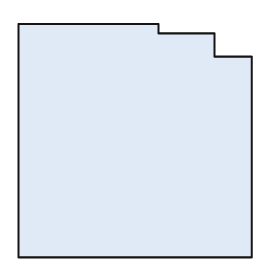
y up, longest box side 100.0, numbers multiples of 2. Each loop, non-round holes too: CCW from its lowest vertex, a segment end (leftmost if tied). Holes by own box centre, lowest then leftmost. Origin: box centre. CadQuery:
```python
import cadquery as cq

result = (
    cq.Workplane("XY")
    .moveTo(-50.0, -50.0)
    .lineTo(50.0, -50.0)
    .lineTo(50.0, 36.0)
    .lineTo(34.0, 36.0)
    .lineTo(34.0, 46.0)
    .lineTo(10.0, 46.0)
    .lineTo(10.0, 50.0)
    .lineTo(-50.0, 50.0)
    .close()
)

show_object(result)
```